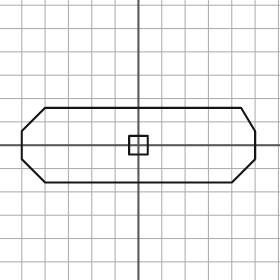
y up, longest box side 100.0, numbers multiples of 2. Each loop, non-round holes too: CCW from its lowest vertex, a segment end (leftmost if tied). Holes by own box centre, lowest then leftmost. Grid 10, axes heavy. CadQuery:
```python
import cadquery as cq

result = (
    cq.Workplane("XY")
    .moveTo(-40.0, -16.0)
    .lineTo(40.0, -16.0)
    .lineTo(50.0, -6.0)
    .lineTo(50.0, 6.0)
    .lineTo(44.0, 16.0)
    .lineTo(-40.0, 16.0)
    .lineTo(-50.0, 6.0)
    .lineTo(-50.0, -6.0)
    .close()
    .moveTo(-4.0, -4.0)
    .lineTo(4.0, -4.0)
    .lineTo(4.0, 4.0)
    .lineTo(-4.0, 4.0)
    .close()
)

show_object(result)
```